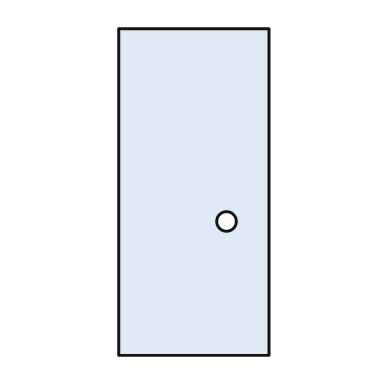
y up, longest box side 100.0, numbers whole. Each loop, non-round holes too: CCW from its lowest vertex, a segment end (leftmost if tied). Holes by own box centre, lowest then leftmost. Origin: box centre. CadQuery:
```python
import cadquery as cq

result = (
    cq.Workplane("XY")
    .moveTo(-23.0, -50.0)
    .lineTo(23.0, -50.0)
    .lineTo(23.0, 50.0)
    .lineTo(-23.0, 50.0)
    .close()
    .moveTo(10.0, -9.0)
    .circle(3.0)
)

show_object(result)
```